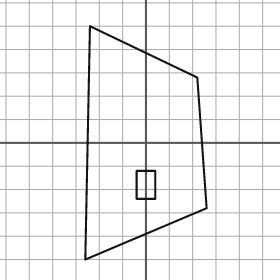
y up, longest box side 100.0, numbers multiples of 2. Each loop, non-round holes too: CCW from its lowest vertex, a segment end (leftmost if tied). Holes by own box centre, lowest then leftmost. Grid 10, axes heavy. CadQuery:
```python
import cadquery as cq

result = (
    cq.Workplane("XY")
    .moveTo(-26.0, -50.0)
    .lineTo(26.0, -28.0)
    .lineTo(22.0, 28.0)
    .lineTo(-24.0, 50.0)
    .close()
    .moveTo(-4.0, -24.0)
    .lineTo(4.0, -24.0)
    .lineTo(4.0, -12.0)
    .lineTo(-4.0, -12.0)
    .close()
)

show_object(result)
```